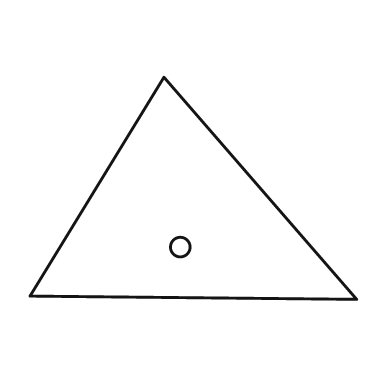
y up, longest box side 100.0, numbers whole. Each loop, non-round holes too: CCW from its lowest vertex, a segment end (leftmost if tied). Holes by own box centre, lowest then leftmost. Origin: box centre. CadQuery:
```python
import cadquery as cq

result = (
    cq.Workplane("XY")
    .moveTo(50.0, -34.0)
    .lineTo(-9.0, 34.0)
    .lineTo(-50.0, -33.0)
    .close()
    .moveTo(-4.0, -18.0)
    .circle(3.0)
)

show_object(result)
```